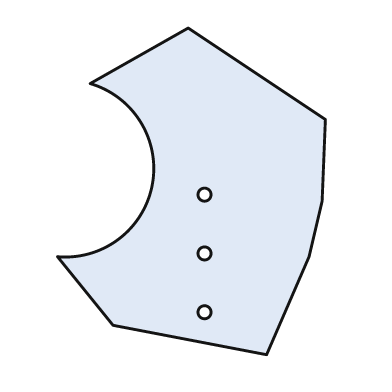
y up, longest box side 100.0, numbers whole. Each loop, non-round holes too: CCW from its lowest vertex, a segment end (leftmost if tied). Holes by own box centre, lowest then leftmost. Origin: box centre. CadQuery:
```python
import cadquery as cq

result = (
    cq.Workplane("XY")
    .moveTo(23.0, -50.0)
    .lineTo(36.0, -20.0)
    .lineTo(40.0, -3.0)
    .lineTo(41.0, 22.0)
    .lineTo(-1.0, 50.0)
    .lineTo(-31.0, 33.0)
    .threePointArc((-12.0, 2.0), (-41.0, -20.0))
    .lineTo(-24.0, -41.0)
    .close()
    .moveTo(4.0, -37.0)
    .circle(2.0)
    .moveTo(4.0, -19.0)
    .circle(2.0)
    .moveTo(4.0, -1.0)
    .circle(2.0)
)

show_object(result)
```